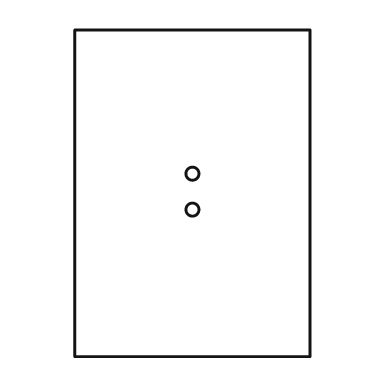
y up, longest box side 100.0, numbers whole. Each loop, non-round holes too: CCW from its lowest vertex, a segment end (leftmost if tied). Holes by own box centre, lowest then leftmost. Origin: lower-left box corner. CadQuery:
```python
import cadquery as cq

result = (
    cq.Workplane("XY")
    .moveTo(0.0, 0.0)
    .lineTo(72.0, 0.0)
    .lineTo(72.0, 100.0)
    .lineTo(0.0, 100.0)
    .close()
    .moveTo(36.0, 45.0)
    .circle(2.0)
    .moveTo(36.0, 56.0)
    .circle(2.0)
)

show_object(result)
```